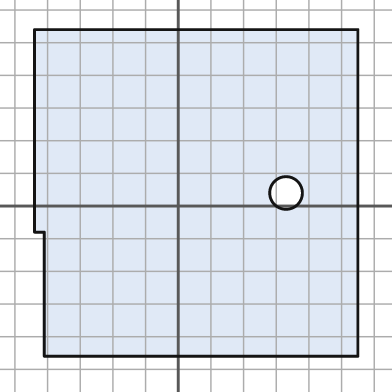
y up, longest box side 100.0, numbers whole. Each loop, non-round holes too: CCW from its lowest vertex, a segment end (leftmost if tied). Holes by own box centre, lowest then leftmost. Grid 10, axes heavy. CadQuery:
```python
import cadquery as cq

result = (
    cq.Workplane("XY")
    .moveTo(-41.0, -46.0)
    .lineTo(55.0, -46.0)
    .lineTo(55.0, 54.0)
    .lineTo(-44.0, 54.0)
    .lineTo(-44.0, -8.0)
    .lineTo(-41.0, -8.0)
    .close()
    .moveTo(33.0, 4.0)
    .circle(5.0)
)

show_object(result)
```